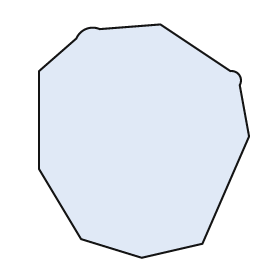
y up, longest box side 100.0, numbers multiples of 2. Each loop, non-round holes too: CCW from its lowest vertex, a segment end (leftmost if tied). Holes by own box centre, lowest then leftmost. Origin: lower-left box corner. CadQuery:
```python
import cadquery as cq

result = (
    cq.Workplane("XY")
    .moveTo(44.0, 0.0)
    .lineTo(70.0, 6.0)
    .lineTo(90.0, 52.0)
    .lineTo(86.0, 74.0)
    .threePointArc((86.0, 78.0), (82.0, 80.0))
    .lineTo(52.0, 100.0)
    .lineTo(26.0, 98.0)
    .threePointArc((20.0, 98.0), (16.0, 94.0))
    .lineTo(0.0, 80.0)
    .lineTo(0.0, 38.0)
    .lineTo(18.0, 8.0)
    .close()
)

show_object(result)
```